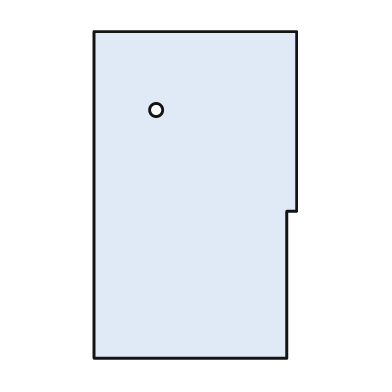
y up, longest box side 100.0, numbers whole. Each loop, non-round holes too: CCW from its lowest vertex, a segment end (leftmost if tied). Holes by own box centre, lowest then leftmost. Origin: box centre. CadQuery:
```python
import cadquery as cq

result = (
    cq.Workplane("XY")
    .moveTo(-31.0, -50.0)
    .lineTo(28.0, -50.0)
    .lineTo(28.0, -5.0)
    .lineTo(31.0, -5.0)
    .lineTo(31.0, 50.0)
    .lineTo(-31.0, 50.0)
    .close()
    .moveTo(-12.0, 26.0)
    .circle(2.0)
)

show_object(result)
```